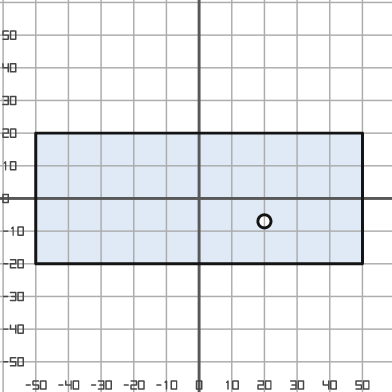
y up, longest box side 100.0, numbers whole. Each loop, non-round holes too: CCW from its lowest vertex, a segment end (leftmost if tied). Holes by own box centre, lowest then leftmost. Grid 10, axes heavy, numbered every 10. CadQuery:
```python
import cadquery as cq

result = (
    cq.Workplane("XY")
    .moveTo(-50.0, -20.0)
    .lineTo(50.0, -20.0)
    .lineTo(50.0, 20.0)
    .lineTo(-50.0, 20.0)
    .close()
    .moveTo(20.0, -7.0)
    .circle(2.0)
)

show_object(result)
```